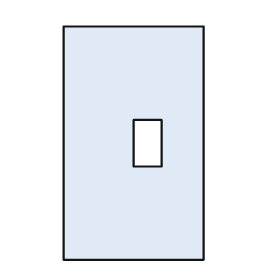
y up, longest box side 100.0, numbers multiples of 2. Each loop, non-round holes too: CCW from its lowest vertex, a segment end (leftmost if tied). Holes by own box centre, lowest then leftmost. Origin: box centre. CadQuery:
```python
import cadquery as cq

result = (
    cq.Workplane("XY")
    .moveTo(-30.0, -50.0)
    .lineTo(30.0, -50.0)
    .lineTo(30.0, 50.0)
    .lineTo(-30.0, 50.0)
    .close()
    .moveTo(0.0, -10.0)
    .lineTo(12.0, -10.0)
    .lineTo(12.0, 10.0)
    .lineTo(0.0, 10.0)
    .close()
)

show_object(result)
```